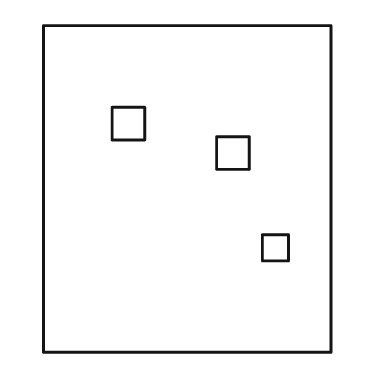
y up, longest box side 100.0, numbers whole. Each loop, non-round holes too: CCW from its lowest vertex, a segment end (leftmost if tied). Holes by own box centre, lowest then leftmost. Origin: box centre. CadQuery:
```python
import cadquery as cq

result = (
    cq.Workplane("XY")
    .moveTo(-44.0, -50.0)
    .lineTo(44.0, -50.0)
    .lineTo(44.0, 50.0)
    .lineTo(-44.0, 50.0)
    .close()
    .moveTo(23.0, -22.0)
    .lineTo(31.0, -22.0)
    .lineTo(31.0, -14.0)
    .lineTo(23.0, -14.0)
    .close()
    .moveTo(9.0, 6.0)
    .lineTo(19.0, 6.0)
    .lineTo(19.0, 16.0)
    .lineTo(9.0, 16.0)
    .close()
    .moveTo(-23.0, 15.0)
    .lineTo(-13.0, 15.0)
    .lineTo(-13.0, 25.0)
    .lineTo(-23.0, 25.0)
    .close()
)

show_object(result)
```